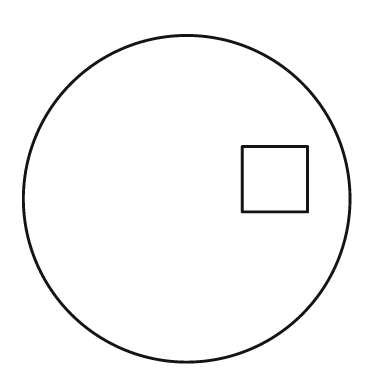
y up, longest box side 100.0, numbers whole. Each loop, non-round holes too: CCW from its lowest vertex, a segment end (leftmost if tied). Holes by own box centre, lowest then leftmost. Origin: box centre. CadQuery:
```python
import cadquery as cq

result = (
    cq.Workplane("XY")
    .moveTo(0.0, 0.0)
    .circle(50.0)
    .moveTo(17.0, -4.0)
    .lineTo(37.0, -4.0)
    .lineTo(37.0, 16.0)
    .lineTo(17.0, 16.0)
    .close()
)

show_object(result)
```